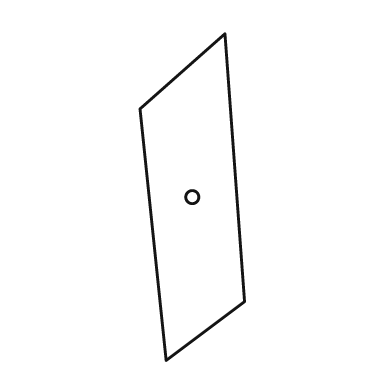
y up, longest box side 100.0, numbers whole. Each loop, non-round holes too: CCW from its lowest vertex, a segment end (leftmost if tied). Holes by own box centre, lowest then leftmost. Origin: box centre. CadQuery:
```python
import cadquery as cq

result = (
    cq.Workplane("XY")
    .moveTo(-8.0, -50.0)
    .lineTo(16.0, -32.0)
    .lineTo(10.0, 50.0)
    .lineTo(-16.0, 27.0)
    .close()
    .moveTo(0.0, 0.0)
    .circle(2.0)
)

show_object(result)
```